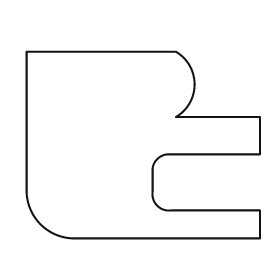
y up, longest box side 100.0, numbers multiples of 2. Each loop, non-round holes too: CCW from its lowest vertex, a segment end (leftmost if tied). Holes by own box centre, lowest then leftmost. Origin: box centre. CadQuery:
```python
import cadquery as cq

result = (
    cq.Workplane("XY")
    .moveTo(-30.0, -40.0)
    .lineTo(50.0, -40.0)
    .lineTo(50.0, -28.0)
    .lineTo(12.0, -28.0)
    .threePointArc((6.0, -26.0), (4.0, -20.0))
    .lineTo(4.0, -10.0)
    .threePointArc((6.0, -6.0), (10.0, -4.0))
    .lineTo(50.0, -4.0)
    .lineTo(50.0, 12.0)
    .lineTo(14.0, 12.0)
    .threePointArc((22.0, 26.0), (14.0, 40.0))
    .lineTo(-50.0, 40.0)
    .lineTo(-50.0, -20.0)
    .threePointArc((-44.0, -34.0), (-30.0, -40.0))
    .close()
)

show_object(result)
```